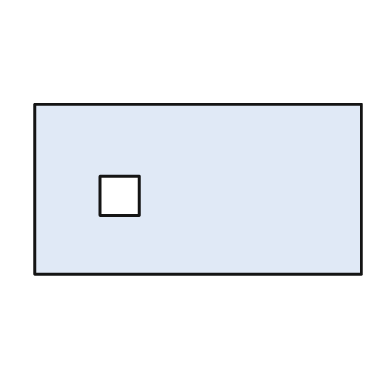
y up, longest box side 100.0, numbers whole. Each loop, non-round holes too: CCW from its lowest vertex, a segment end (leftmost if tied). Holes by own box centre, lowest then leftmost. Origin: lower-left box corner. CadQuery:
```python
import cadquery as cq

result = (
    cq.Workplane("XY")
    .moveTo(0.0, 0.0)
    .lineTo(100.0, 0.0)
    .lineTo(100.0, 52.0)
    .lineTo(0.0, 52.0)
    .close()
    .moveTo(20.0, 18.0)
    .lineTo(32.0, 18.0)
    .lineTo(32.0, 30.0)
    .lineTo(20.0, 30.0)
    .close()
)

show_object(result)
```